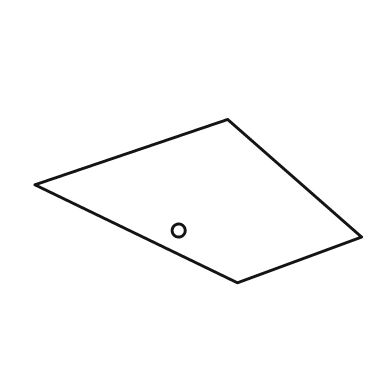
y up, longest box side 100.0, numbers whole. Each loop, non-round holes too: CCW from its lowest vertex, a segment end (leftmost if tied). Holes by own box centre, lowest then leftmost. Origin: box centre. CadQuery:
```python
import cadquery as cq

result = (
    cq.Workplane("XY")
    .moveTo(12.0, -25.0)
    .lineTo(50.0, -11.0)
    .lineTo(9.0, 25.0)
    .lineTo(-50.0, 5.0)
    .close()
    .moveTo(-6.0, -9.0)
    .circle(2.0)
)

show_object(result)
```